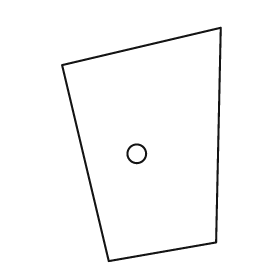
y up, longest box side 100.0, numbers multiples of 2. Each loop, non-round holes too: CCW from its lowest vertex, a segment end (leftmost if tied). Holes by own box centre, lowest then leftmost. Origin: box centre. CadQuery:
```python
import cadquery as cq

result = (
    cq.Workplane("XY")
    .moveTo(-14.0, -50.0)
    .lineTo(32.0, -42.0)
    .lineTo(34.0, 50.0)
    .lineTo(-34.0, 34.0)
    .close()
    .moveTo(-2.0, -4.0)
    .circle(4.0)
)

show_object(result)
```